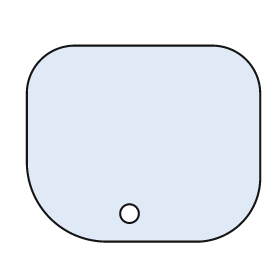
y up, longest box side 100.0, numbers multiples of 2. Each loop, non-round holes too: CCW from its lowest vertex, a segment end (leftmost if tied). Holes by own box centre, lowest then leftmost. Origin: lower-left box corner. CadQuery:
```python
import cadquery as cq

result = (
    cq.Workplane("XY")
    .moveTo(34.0, 0.0)
    .lineTo(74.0, 0.0)
    .threePointArc((92.0, 8.0), (100.0, 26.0))
    .lineTo(100.0, 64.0)
    .threePointArc((94.0, 78.0), (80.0, 84.0))
    .lineTo(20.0, 84.0)
    .threePointArc((6.0, 78.0), (0.0, 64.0))
    .lineTo(0.0, 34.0)
    .threePointArc((10.0, 10.0), (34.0, 0.0))
    .close()
    .moveTo(44.0, 12.0)
    .circle(4.0)
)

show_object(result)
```